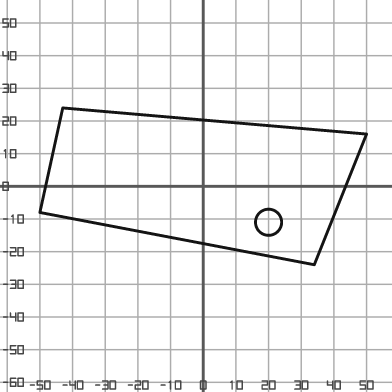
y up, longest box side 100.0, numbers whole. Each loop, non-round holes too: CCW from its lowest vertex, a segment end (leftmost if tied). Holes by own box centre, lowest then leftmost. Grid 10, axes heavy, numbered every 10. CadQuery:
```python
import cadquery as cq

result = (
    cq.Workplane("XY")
    .moveTo(34.0, -24.0)
    .lineTo(50.0, 16.0)
    .lineTo(-43.0, 24.0)
    .lineTo(-50.0, -8.0)
    .close()
    .moveTo(20.0, -11.0)
    .circle(4.0)
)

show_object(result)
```